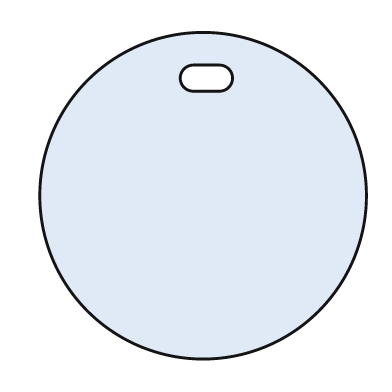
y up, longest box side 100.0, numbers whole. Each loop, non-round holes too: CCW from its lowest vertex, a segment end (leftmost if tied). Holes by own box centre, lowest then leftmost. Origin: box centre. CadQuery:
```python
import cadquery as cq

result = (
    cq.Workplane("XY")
    .moveTo(0.0, 0.0)
    .circle(50.0)
    .moveTo(-3.0, 32.0)
    .lineTo(5.0, 32.0)
    .threePointArc((9.0, 36.0), (5.0, 40.0))
    .lineTo(-3.0, 40.0)
    .threePointArc((-7.0, 36.0), (-3.0, 32.0))
    .close()
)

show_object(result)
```